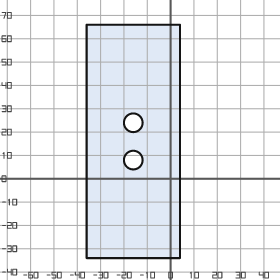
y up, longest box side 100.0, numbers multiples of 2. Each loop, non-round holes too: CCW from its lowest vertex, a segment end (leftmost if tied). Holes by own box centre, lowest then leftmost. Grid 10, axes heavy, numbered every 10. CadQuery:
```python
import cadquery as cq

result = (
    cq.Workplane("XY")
    .moveTo(-36.0, -34.0)
    .lineTo(4.0, -34.0)
    .lineTo(4.0, 66.0)
    .lineTo(-36.0, 66.0)
    .close()
    .moveTo(-16.0, 8.0)
    .circle(4.0)
    .moveTo(-16.0, 24.0)
    .circle(4.0)
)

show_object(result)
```